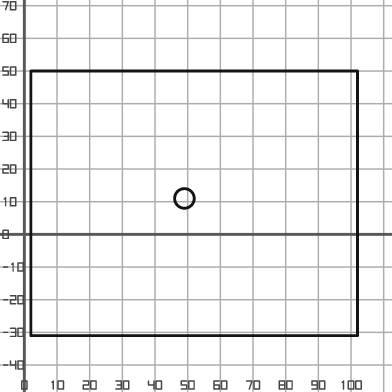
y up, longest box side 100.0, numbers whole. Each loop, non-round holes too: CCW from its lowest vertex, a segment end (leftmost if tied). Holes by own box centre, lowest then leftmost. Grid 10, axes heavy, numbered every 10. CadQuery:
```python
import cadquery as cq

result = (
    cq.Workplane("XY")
    .moveTo(2.0, -31.0)
    .lineTo(102.0, -31.0)
    .lineTo(102.0, 50.0)
    .lineTo(2.0, 50.0)
    .close()
    .moveTo(49.0, 11.0)
    .circle(3.0)
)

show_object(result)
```